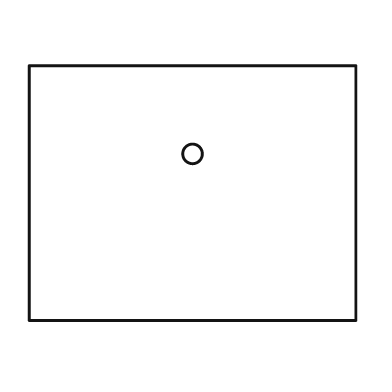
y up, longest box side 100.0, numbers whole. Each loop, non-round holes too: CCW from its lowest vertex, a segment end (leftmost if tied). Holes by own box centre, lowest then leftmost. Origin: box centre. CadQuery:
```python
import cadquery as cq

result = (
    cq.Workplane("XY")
    .moveTo(-50.0, -39.0)
    .lineTo(50.0, -39.0)
    .lineTo(50.0, 39.0)
    .lineTo(-50.0, 39.0)
    .close()
    .moveTo(0.0, 12.0)
    .circle(3.0)
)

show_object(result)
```